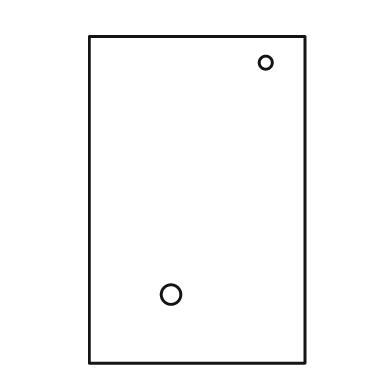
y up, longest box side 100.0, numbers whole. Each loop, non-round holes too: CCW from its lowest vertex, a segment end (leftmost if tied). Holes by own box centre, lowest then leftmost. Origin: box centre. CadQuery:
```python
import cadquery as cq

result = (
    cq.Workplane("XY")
    .moveTo(-33.0, -50.0)
    .lineTo(33.0, -50.0)
    .lineTo(33.0, 50.0)
    .lineTo(-33.0, 50.0)
    .close()
    .moveTo(-8.0, -29.0)
    .circle(3.0)
    .moveTo(21.0, 42.0)
    .circle(2.0)
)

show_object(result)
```